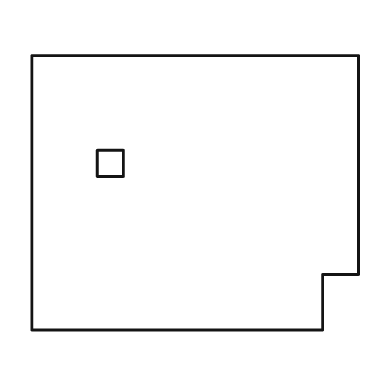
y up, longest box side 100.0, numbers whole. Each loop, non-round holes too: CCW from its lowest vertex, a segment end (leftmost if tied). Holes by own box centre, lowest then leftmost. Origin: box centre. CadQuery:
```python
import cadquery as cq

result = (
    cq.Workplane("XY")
    .moveTo(-50.0, -42.0)
    .lineTo(39.0, -42.0)
    .lineTo(39.0, -25.0)
    .lineTo(50.0, -25.0)
    .lineTo(50.0, 42.0)
    .lineTo(-50.0, 42.0)
    .close()
    .moveTo(-30.0, 5.0)
    .lineTo(-22.0, 5.0)
    .lineTo(-22.0, 13.0)
    .lineTo(-30.0, 13.0)
    .close()
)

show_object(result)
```